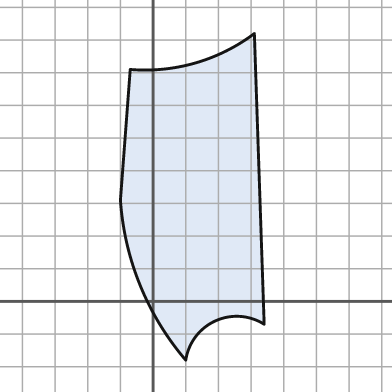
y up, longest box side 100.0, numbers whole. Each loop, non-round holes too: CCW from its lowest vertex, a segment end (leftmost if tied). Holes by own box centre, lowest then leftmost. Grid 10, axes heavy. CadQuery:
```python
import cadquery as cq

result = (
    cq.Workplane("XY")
    .moveTo(10.0, -18.0)
    .threePointArc((19.0, -6.0), (34.0, -7.0))
    .lineTo(31.0, 82.0)
    .threePointArc((13.0, 73.0), (-7.0, 71.0))
    .lineTo(-10.0, 31.0)
    .threePointArc((-4.0, 5.0), (10.0, -18.0))
    .close()
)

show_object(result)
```